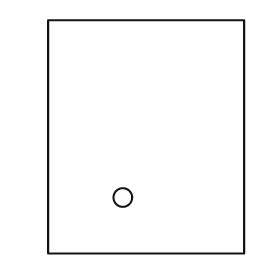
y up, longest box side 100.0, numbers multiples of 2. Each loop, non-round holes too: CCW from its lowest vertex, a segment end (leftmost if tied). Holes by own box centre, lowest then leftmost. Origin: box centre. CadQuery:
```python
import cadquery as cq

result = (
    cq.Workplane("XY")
    .moveTo(-42.0, -50.0)
    .lineTo(42.0, -50.0)
    .lineTo(42.0, 50.0)
    .lineTo(-42.0, 50.0)
    .close()
    .moveTo(-10.0, -26.0)
    .circle(4.0)
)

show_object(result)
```